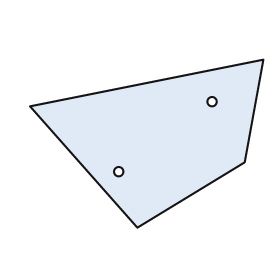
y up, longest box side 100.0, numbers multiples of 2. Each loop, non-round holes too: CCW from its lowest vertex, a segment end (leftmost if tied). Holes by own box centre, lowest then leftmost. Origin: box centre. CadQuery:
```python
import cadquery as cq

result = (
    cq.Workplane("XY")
    .moveTo(-4.0, -36.0)
    .lineTo(42.0, -8.0)
    .lineTo(50.0, 36.0)
    .lineTo(-50.0, 16.0)
    .close()
    .moveTo(-12.0, -12.0)
    .circle(2.0)
    .moveTo(28.0, 18.0)
    .circle(2.0)
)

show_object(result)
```